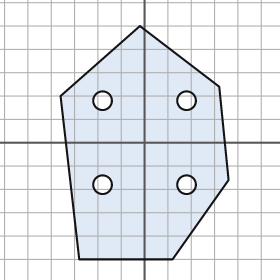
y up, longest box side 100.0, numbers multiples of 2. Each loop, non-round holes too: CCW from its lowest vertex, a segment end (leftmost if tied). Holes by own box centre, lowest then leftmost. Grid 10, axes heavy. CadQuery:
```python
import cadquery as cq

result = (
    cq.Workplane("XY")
    .moveTo(-28.0, -50.0)
    .lineTo(12.0, -50.0)
    .lineTo(36.0, -16.0)
    .lineTo(32.0, 24.0)
    .lineTo(-2.0, 50.0)
    .lineTo(-36.0, 20.0)
    .close()
    .moveTo(-18.0, -18.0)
    .circle(4.0)
    .moveTo(18.0, -18.0)
    .circle(4.0)
    .moveTo(-18.0, 18.0)
    .circle(4.0)
    .moveTo(18.0, 18.0)
    .circle(4.0)
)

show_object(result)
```